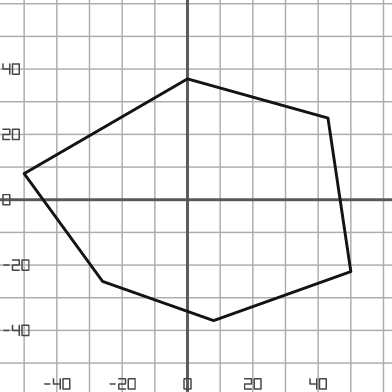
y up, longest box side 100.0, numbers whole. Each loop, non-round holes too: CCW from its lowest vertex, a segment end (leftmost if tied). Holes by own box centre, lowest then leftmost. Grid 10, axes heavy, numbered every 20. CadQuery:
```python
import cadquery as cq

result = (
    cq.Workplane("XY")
    .moveTo(8.0, -37.0)
    .lineTo(50.0, -22.0)
    .lineTo(43.0, 25.0)
    .lineTo(0.0, 37.0)
    .lineTo(-50.0, 8.0)
    .lineTo(-26.0, -25.0)
    .close()
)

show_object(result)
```